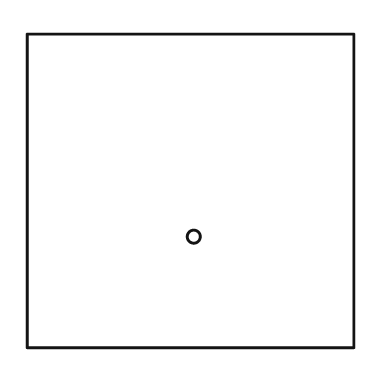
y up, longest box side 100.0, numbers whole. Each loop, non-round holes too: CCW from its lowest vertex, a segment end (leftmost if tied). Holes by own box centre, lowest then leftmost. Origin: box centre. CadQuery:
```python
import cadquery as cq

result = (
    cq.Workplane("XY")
    .moveTo(-50.0, -48.0)
    .lineTo(50.0, -48.0)
    .lineTo(50.0, 48.0)
    .lineTo(-50.0, 48.0)
    .close()
    .moveTo(1.0, -14.0)
    .circle(2.0)
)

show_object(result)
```